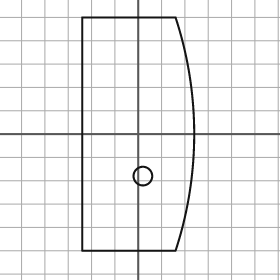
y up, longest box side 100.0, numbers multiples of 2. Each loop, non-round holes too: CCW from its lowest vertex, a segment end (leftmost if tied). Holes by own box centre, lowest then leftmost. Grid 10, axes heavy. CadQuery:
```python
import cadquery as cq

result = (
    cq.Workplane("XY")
    .moveTo(-24.0, -50.0)
    .lineTo(16.0, -50.0)
    .threePointArc((24.0, 0.0), (16.0, 50.0))
    .lineTo(-24.0, 50.0)
    .close()
    .moveTo(2.0, -18.0)
    .circle(4.0)
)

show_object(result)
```